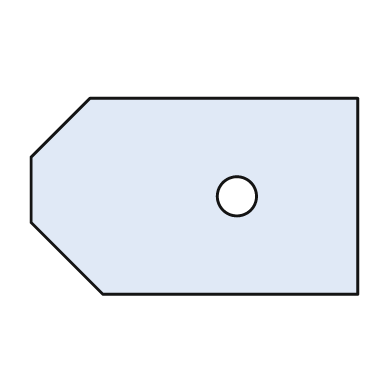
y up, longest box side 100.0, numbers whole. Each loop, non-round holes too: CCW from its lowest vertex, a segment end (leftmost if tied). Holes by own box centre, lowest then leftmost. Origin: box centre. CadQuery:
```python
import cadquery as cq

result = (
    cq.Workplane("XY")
    .moveTo(-28.0, -30.0)
    .lineTo(50.0, -30.0)
    .lineTo(50.0, 30.0)
    .lineTo(-32.0, 30.0)
    .lineTo(-50.0, 12.0)
    .lineTo(-50.0, -8.0)
    .close()
    .moveTo(13.0, 0.0)
    .circle(6.0)
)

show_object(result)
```